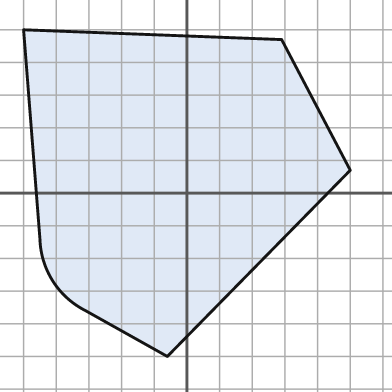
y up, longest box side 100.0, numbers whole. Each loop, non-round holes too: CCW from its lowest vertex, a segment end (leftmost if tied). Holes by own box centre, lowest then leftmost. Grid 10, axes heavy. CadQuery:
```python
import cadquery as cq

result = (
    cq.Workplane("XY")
    .moveTo(-6.0, -50.0)
    .lineTo(50.0, 7.0)
    .lineTo(29.0, 47.0)
    .lineTo(-50.0, 50.0)
    .lineTo(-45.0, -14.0)
    .threePointArc((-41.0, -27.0), (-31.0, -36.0))
    .close()
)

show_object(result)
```